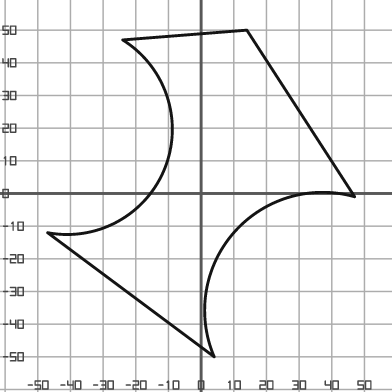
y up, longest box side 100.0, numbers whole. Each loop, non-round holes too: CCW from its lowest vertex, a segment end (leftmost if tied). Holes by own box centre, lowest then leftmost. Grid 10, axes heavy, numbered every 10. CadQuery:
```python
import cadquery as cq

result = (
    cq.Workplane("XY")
    .moveTo(4.0, -50.0)
    .threePointArc((10.0, -12.0), (47.0, -1.0))
    .lineTo(14.0, 50.0)
    .lineTo(-24.0, 47.0)
    .threePointArc((-11.0, 8.0), (-47.0, -12.0))
    .close()
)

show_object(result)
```